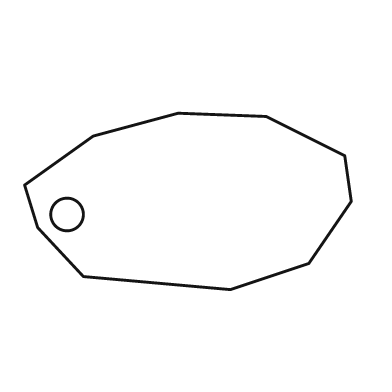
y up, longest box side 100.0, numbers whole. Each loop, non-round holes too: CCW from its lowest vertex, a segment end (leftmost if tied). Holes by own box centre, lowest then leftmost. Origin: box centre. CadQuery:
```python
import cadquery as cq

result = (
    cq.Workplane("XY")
    .moveTo(13.0, -27.0)
    .lineTo(37.0, -19.0)
    .lineTo(50.0, 0.0)
    .lineTo(48.0, 14.0)
    .lineTo(24.0, 26.0)
    .lineTo(-3.0, 27.0)
    .lineTo(-29.0, 20.0)
    .lineTo(-50.0, 5.0)
    .lineTo(-46.0, -8.0)
    .lineTo(-32.0, -23.0)
    .close()
    .moveTo(-37.0, -4.0)
    .circle(5.0)
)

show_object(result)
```